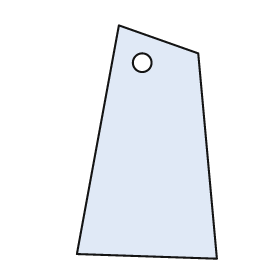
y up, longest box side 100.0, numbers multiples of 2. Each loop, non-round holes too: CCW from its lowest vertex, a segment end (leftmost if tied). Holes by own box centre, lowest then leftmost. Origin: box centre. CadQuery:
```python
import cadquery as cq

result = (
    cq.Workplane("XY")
    .moveTo(30.0, -50.0)
    .lineTo(22.0, 38.0)
    .lineTo(-12.0, 50.0)
    .lineTo(-30.0, -48.0)
    .close()
    .moveTo(-2.0, 34.0)
    .circle(4.0)
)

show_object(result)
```